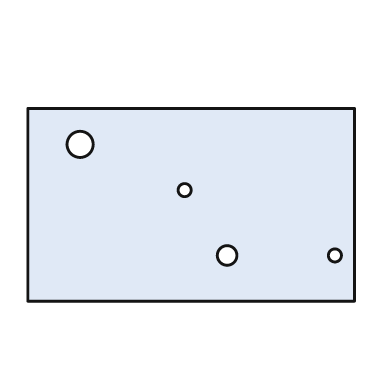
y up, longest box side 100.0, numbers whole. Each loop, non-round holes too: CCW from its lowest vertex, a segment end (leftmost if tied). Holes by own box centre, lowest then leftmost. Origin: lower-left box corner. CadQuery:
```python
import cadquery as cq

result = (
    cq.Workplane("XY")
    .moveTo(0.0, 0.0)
    .lineTo(100.0, 0.0)
    .lineTo(100.0, 59.0)
    .lineTo(0.0, 59.0)
    .close()
    .moveTo(61.0, 14.0)
    .circle(3.0)
    .moveTo(94.0, 14.0)
    .circle(2.0)
    .moveTo(48.0, 34.0)
    .circle(2.0)
    .moveTo(16.0, 48.0)
    .circle(4.0)
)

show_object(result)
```